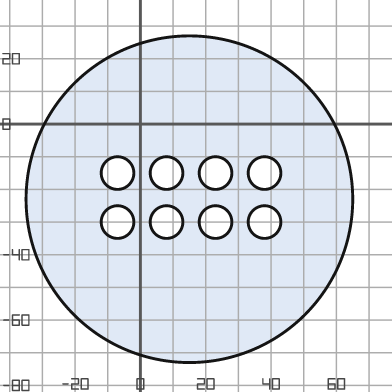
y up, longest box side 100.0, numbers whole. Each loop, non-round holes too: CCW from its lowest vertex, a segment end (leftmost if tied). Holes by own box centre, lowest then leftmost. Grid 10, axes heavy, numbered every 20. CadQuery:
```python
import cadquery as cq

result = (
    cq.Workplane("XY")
    .moveTo(15.0, -23.0)
    .circle(50.0)
    .moveTo(-7.0, -30.0)
    .circle(5.0)
    .moveTo(8.0, -30.0)
    .circle(5.0)
    .moveTo(23.0, -30.0)
    .circle(5.0)
    .moveTo(38.0, -30.0)
    .circle(5.0)
    .moveTo(-7.0, -15.0)
    .circle(5.0)
    .moveTo(8.0, -15.0)
    .circle(5.0)
    .moveTo(23.0, -15.0)
    .circle(5.0)
    .moveTo(38.0, -15.0)
    .circle(5.0)
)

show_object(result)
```